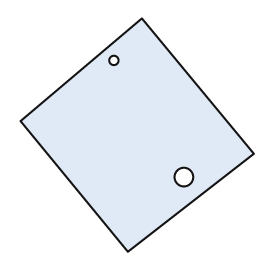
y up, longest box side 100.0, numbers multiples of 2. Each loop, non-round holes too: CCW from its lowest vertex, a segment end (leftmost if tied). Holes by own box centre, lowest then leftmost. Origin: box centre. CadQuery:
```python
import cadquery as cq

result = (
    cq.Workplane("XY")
    .moveTo(-4.0, -50.0)
    .lineTo(50.0, -8.0)
    .lineTo(2.0, 50.0)
    .lineTo(-50.0, 6.0)
    .close()
    .moveTo(20.0, -18.0)
    .circle(4.0)
    .moveTo(-10.0, 32.0)
    .circle(2.0)
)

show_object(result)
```